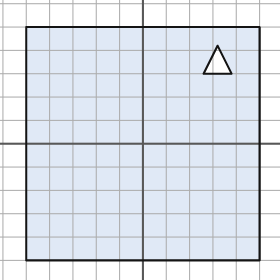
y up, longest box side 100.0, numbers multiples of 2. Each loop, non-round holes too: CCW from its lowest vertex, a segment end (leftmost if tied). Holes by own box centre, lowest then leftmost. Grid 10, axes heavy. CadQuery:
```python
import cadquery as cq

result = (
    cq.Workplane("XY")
    .moveTo(-50.0, -50.0)
    .lineTo(50.0, -50.0)
    .lineTo(50.0, 50.0)
    .lineTo(-50.0, 50.0)
    .close()
    .moveTo(26.0, 30.0)
    .lineTo(38.0, 30.0)
    .lineTo(32.0, 42.0)
    .close()
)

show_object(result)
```